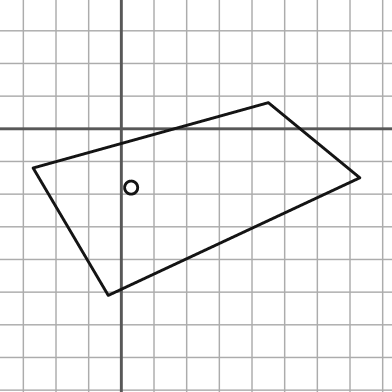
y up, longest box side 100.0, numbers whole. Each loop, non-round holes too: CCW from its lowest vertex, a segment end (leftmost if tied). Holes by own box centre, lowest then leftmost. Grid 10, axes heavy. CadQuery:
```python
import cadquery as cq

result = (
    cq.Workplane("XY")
    .moveTo(-4.0, -51.0)
    .lineTo(73.0, -15.0)
    .lineTo(45.0, 8.0)
    .lineTo(-27.0, -12.0)
    .close()
    .moveTo(3.0, -18.0)
    .circle(2.0)
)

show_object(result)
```